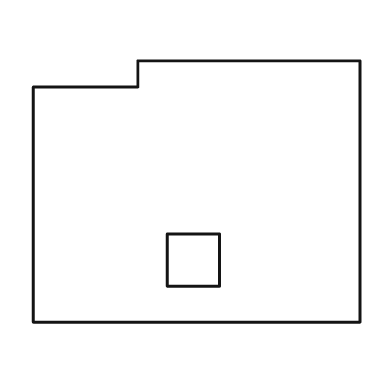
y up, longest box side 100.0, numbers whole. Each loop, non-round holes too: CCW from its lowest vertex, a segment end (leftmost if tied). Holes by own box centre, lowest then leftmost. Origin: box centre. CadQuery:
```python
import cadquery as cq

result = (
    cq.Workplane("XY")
    .moveTo(-50.0, -40.0)
    .lineTo(50.0, -40.0)
    .lineTo(50.0, 40.0)
    .lineTo(-18.0, 40.0)
    .lineTo(-18.0, 32.0)
    .lineTo(-50.0, 32.0)
    .close()
    .moveTo(-9.0, -29.0)
    .lineTo(7.0, -29.0)
    .lineTo(7.0, -13.0)
    .lineTo(-9.0, -13.0)
    .close()
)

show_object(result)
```